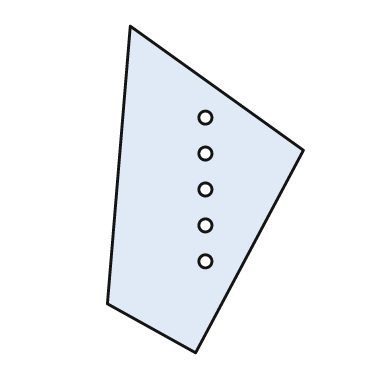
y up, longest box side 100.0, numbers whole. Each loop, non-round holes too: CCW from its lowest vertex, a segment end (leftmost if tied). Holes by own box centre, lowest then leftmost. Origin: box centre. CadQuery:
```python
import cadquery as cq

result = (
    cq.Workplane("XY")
    .moveTo(-3.0, -50.0)
    .lineTo(30.0, 12.0)
    .lineTo(-23.0, 50.0)
    .lineTo(-30.0, -35.0)
    .close()
    .moveTo(0.0, -22.0)
    .circle(2.0)
    .moveTo(0.0, -11.0)
    .circle(2.0)
    .moveTo(0.0, 0.0)
    .circle(2.0)
    .moveTo(0.0, 11.0)
    .circle(2.0)
    .moveTo(0.0, 22.0)
    .circle(2.0)
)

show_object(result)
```